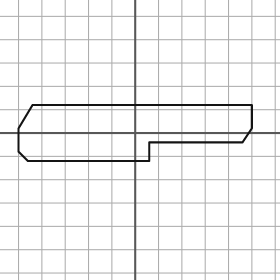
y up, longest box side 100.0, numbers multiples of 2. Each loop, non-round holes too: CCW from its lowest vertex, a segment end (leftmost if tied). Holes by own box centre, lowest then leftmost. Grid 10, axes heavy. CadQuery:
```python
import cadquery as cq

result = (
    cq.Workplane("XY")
    .moveTo(-46.0, -12.0)
    .lineTo(6.0, -12.0)
    .lineTo(6.0, -4.0)
    .lineTo(46.0, -4.0)
    .lineTo(50.0, 2.0)
    .lineTo(50.0, 12.0)
    .lineTo(-44.0, 12.0)
    .lineTo(-50.0, 2.0)
    .lineTo(-50.0, -8.0)
    .close()
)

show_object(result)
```